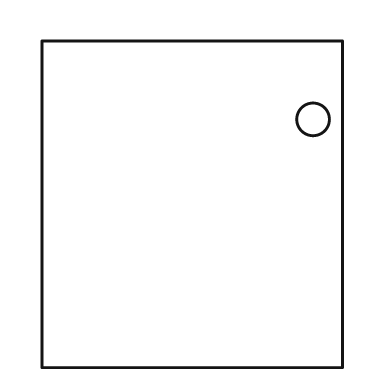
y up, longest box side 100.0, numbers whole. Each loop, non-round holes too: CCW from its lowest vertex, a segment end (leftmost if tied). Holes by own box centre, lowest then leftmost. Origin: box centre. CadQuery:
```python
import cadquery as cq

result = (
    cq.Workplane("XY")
    .moveTo(-46.0, -50.0)
    .lineTo(46.0, -50.0)
    .lineTo(46.0, 50.0)
    .lineTo(-46.0, 50.0)
    .close()
    .moveTo(37.0, 26.0)
    .circle(5.0)
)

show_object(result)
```